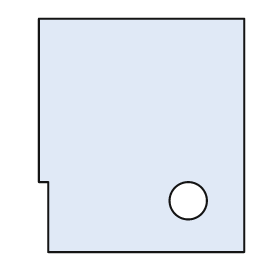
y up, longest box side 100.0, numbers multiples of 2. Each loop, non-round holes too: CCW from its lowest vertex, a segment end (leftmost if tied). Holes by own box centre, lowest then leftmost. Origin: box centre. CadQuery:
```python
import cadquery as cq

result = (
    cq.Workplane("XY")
    .moveTo(-40.0, -50.0)
    .lineTo(44.0, -50.0)
    .lineTo(44.0, 50.0)
    .lineTo(-44.0, 50.0)
    .lineTo(-44.0, -20.0)
    .lineTo(-40.0, -20.0)
    .close()
    .moveTo(20.0, -28.0)
    .circle(8.0)
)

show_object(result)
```